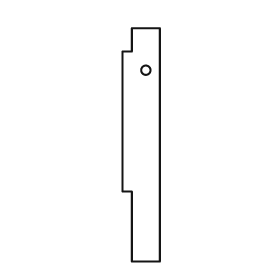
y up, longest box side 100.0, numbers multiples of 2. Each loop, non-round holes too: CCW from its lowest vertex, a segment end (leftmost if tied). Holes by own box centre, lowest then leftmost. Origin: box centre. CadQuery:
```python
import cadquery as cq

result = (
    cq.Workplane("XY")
    .moveTo(-4.0, -50.0)
    .lineTo(8.0, -50.0)
    .lineTo(8.0, 50.0)
    .lineTo(-4.0, 50.0)
    .lineTo(-4.0, 40.0)
    .lineTo(-8.0, 40.0)
    .lineTo(-8.0, -20.0)
    .lineTo(-4.0, -20.0)
    .close()
    .moveTo(2.0, 32.0)
    .circle(2.0)
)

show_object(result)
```